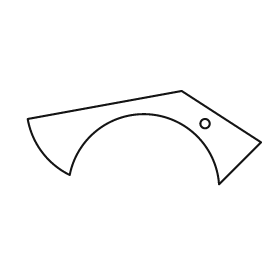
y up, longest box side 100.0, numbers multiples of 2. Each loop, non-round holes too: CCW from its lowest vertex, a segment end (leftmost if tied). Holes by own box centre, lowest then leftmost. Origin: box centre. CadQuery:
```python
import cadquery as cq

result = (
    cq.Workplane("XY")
    .moveTo(32.0, -20.0)
    .lineTo(50.0, -2.0)
    .lineTo(16.0, 20.0)
    .lineTo(-50.0, 8.0)
    .threePointArc((-44.0, -6.0), (-32.0, -16.0))
    .threePointArc((2.0, 10.0), (32.0, -20.0))
    .close()
    .moveTo(26.0, 6.0)
    .circle(2.0)
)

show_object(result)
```